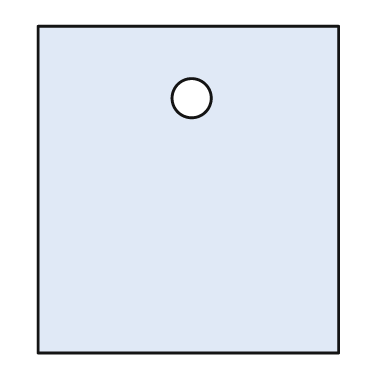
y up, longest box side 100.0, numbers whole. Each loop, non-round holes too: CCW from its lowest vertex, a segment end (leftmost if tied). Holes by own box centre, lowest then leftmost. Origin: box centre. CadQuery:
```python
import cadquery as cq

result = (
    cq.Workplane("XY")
    .moveTo(-46.0, -50.0)
    .lineTo(46.0, -50.0)
    .lineTo(46.0, 50.0)
    .lineTo(-46.0, 50.0)
    .close()
    .moveTo(1.0, 28.0)
    .circle(6.0)
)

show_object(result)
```